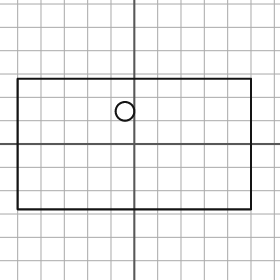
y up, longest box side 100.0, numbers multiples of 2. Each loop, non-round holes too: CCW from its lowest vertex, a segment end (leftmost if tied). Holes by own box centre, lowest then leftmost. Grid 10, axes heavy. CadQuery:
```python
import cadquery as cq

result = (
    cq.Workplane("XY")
    .moveTo(-50.0, -28.0)
    .lineTo(50.0, -28.0)
    .lineTo(50.0, 28.0)
    .lineTo(-50.0, 28.0)
    .close()
    .moveTo(-4.0, 14.0)
    .circle(4.0)
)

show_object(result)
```